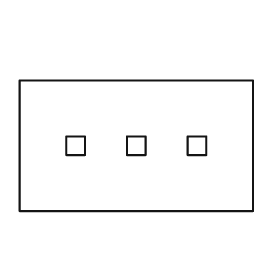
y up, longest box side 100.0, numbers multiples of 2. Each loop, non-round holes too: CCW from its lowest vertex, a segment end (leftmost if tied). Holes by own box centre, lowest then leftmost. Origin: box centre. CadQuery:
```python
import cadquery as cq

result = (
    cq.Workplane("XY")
    .moveTo(-50.0, -28.0)
    .lineTo(50.0, -28.0)
    .lineTo(50.0, 28.0)
    .lineTo(-50.0, 28.0)
    .close()
    .moveTo(-30.0, -4.0)
    .lineTo(-22.0, -4.0)
    .lineTo(-22.0, 4.0)
    .lineTo(-30.0, 4.0)
    .close()
    .moveTo(-4.0, -4.0)
    .lineTo(4.0, -4.0)
    .lineTo(4.0, 4.0)
    .lineTo(-4.0, 4.0)
    .close()
    .moveTo(22.0, -4.0)
    .lineTo(30.0, -4.0)
    .lineTo(30.0, 4.0)
    .lineTo(22.0, 4.0)
    .close()
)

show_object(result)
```